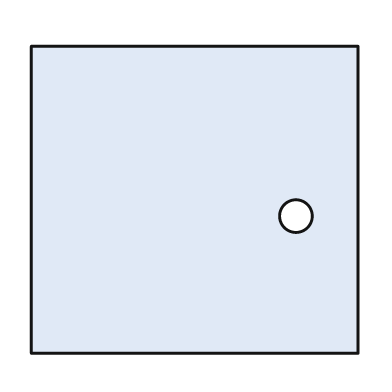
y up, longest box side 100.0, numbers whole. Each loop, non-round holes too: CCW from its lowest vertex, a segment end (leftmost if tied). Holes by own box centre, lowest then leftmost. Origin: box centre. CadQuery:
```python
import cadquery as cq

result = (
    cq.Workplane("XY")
    .moveTo(-50.0, -47.0)
    .lineTo(50.0, -47.0)
    .lineTo(50.0, 47.0)
    .lineTo(-50.0, 47.0)
    .close()
    .moveTo(31.0, -5.0)
    .circle(5.0)
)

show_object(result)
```